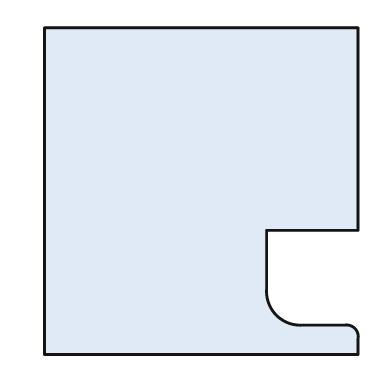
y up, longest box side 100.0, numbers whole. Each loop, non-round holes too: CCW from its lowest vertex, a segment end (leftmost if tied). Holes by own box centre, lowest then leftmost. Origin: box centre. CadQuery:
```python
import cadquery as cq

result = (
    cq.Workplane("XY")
    .moveTo(-48.0, -50.0)
    .lineTo(48.0, -50.0)
    .lineTo(48.0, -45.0)
    .threePointArc((47.0, -42.0), (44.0, -41.0))
    .lineTo(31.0, -41.0)
    .threePointArc((23.0, -38.0), (20.0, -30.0))
    .lineTo(20.0, -12.0)
    .lineTo(48.0, -12.0)
    .lineTo(48.0, 50.0)
    .lineTo(-48.0, 50.0)
    .close()
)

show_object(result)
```